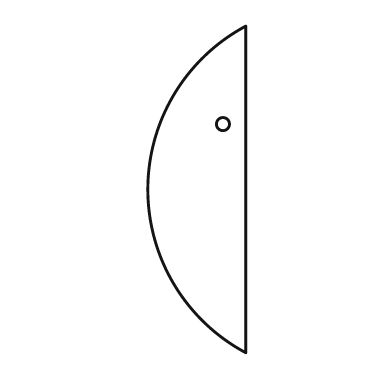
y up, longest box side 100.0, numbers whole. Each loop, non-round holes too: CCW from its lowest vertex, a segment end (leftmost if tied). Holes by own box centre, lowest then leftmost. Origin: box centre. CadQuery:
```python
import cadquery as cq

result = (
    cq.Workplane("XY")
    .moveTo(15.0, -50.0)
    .lineTo(15.0, 50.0)
    .threePointArc((-15.0, 0.0), (15.0, -50.0))
    .close()
    .moveTo(8.0, 20.0)
    .circle(2.0)
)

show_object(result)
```